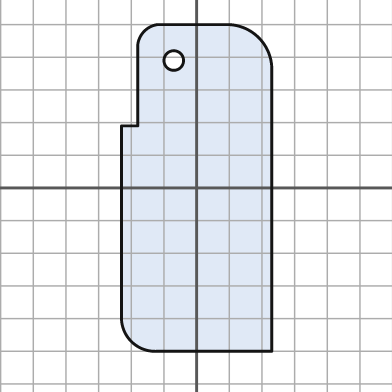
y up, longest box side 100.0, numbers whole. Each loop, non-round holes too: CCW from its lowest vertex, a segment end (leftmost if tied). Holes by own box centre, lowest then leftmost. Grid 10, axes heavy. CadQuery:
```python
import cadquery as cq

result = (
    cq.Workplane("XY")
    .moveTo(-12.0, -50.0)
    .lineTo(23.0, -50.0)
    .lineTo(23.0, 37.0)
    .threePointArc((19.0, 46.0), (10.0, 50.0))
    .lineTo(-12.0, 50.0)
    .threePointArc((-16.0, 48.0), (-18.0, 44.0))
    .lineTo(-18.0, 19.0)
    .lineTo(-23.0, 19.0)
    .lineTo(-23.0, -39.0)
    .threePointArc((-20.0, -47.0), (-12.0, -50.0))
    .close()
    .moveTo(-7.0, 39.0)
    .circle(3.0)
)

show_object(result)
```